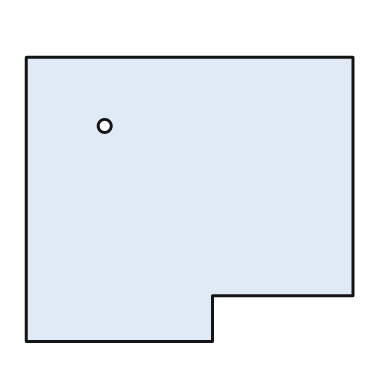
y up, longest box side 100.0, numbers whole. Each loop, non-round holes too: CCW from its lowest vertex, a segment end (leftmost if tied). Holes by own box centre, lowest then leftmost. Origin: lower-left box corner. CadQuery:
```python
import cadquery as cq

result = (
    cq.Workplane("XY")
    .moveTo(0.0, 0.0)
    .lineTo(57.0, 0.0)
    .lineTo(57.0, 14.0)
    .lineTo(100.0, 14.0)
    .lineTo(100.0, 87.0)
    .lineTo(0.0, 87.0)
    .close()
    .moveTo(24.0, 66.0)
    .circle(2.0)
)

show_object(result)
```